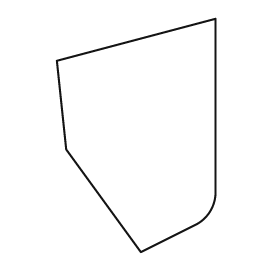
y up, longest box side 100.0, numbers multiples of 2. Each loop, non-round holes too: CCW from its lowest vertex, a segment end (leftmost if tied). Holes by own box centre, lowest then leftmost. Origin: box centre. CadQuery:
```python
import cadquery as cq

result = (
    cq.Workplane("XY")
    .moveTo(2.0, -50.0)
    .lineTo(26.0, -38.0)
    .threePointArc((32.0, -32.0), (34.0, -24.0))
    .lineTo(34.0, 50.0)
    .lineTo(-34.0, 32.0)
    .lineTo(-30.0, -6.0)
    .close()
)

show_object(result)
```